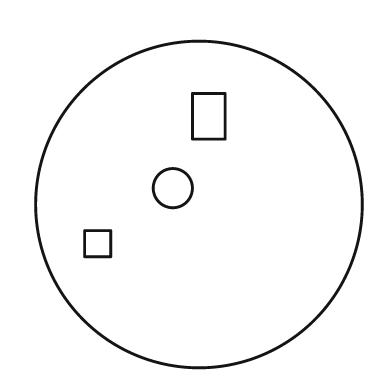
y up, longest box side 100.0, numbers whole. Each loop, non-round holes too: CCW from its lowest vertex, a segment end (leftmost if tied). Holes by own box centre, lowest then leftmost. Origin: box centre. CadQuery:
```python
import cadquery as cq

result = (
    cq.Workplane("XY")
    .moveTo(0.0, 0.0)
    .circle(50.0)
    .moveTo(-35.0, -16.0)
    .lineTo(-27.0, -16.0)
    .lineTo(-27.0, -8.0)
    .lineTo(-35.0, -8.0)
    .close()
    .moveTo(-8.0, 5.0)
    .circle(6.0)
    .moveTo(-2.0, 20.0)
    .lineTo(8.0, 20.0)
    .lineTo(8.0, 34.0)
    .lineTo(-2.0, 34.0)
    .close()
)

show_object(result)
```